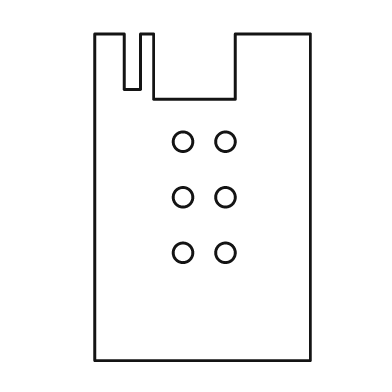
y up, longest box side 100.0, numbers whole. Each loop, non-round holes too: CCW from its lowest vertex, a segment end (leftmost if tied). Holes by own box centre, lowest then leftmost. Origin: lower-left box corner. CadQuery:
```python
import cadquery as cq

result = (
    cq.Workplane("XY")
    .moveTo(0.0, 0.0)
    .lineTo(66.0, 0.0)
    .lineTo(66.0, 100.0)
    .lineTo(43.0, 100.0)
    .lineTo(43.0, 80.0)
    .lineTo(18.0, 80.0)
    .lineTo(18.0, 100.0)
    .lineTo(14.0, 100.0)
    .lineTo(14.0, 83.0)
    .lineTo(9.0, 83.0)
    .lineTo(9.0, 100.0)
    .lineTo(0.0, 100.0)
    .close()
    .moveTo(27.0, 33.0)
    .circle(3.0)
    .moveTo(40.0, 33.0)
    .circle(3.0)
    .moveTo(27.0, 50.0)
    .circle(3.0)
    .moveTo(40.0, 50.0)
    .circle(3.0)
    .moveTo(27.0, 67.0)
    .circle(3.0)
    .moveTo(40.0, 67.0)
    .circle(3.0)
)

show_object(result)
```